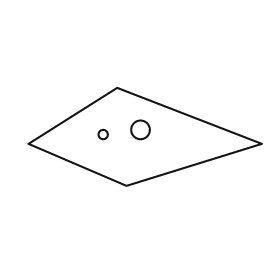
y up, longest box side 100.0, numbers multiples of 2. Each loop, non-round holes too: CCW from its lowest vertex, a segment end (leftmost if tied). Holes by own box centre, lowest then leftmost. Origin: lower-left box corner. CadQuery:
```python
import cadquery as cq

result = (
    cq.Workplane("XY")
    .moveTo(42.0, 0.0)
    .lineTo(100.0, 18.0)
    .lineTo(38.0, 42.0)
    .lineTo(0.0, 18.0)
    .close()
    .moveTo(32.0, 22.0)
    .circle(2.0)
    .moveTo(48.0, 24.0)
    .circle(4.0)
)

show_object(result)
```